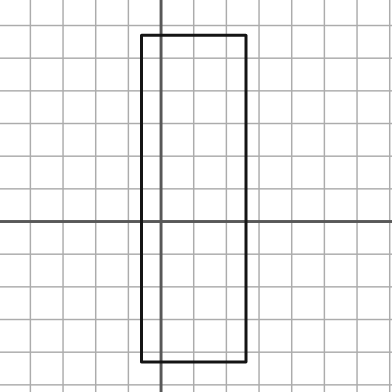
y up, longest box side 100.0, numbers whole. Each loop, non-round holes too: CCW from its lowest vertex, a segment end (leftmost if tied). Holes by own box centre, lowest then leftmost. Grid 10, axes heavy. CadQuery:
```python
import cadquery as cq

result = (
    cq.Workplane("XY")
    .moveTo(-6.0, -43.0)
    .lineTo(26.0, -43.0)
    .lineTo(26.0, 57.0)
    .lineTo(-6.0, 57.0)
    .close()
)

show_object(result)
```